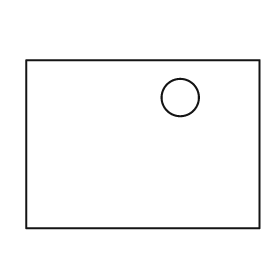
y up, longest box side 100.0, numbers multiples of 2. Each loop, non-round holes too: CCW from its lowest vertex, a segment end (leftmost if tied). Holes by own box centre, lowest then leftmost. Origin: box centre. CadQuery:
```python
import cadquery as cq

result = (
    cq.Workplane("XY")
    .moveTo(-50.0, -36.0)
    .lineTo(50.0, -36.0)
    .lineTo(50.0, 36.0)
    .lineTo(-50.0, 36.0)
    .close()
    .moveTo(16.0, 20.0)
    .circle(8.0)
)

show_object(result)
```